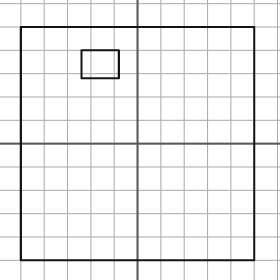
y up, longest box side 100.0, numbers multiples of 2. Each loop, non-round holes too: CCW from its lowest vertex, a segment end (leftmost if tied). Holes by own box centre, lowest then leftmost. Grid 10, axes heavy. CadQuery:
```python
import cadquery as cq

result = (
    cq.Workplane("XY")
    .moveTo(-50.0, -50.0)
    .lineTo(50.0, -50.0)
    .lineTo(50.0, 50.0)
    .lineTo(-50.0, 50.0)
    .close()
    .moveTo(-24.0, 28.0)
    .lineTo(-8.0, 28.0)
    .lineTo(-8.0, 40.0)
    .lineTo(-24.0, 40.0)
    .close()
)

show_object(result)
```